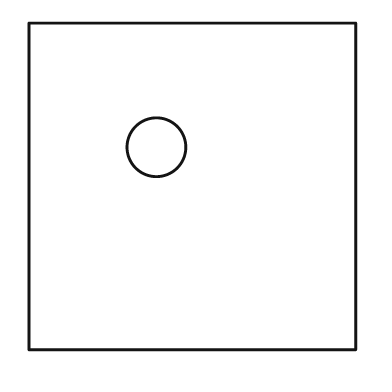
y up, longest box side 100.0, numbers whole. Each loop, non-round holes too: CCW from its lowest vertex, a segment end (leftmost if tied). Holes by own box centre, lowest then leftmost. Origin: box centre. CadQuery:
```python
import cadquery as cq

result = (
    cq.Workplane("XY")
    .moveTo(-50.0, -50.0)
    .lineTo(50.0, -50.0)
    .lineTo(50.0, 50.0)
    .lineTo(-50.0, 50.0)
    .close()
    .moveTo(-11.0, 12.0)
    .circle(9.0)
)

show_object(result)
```